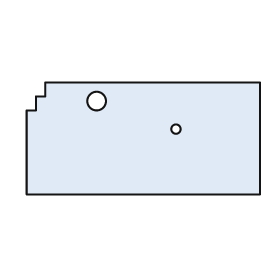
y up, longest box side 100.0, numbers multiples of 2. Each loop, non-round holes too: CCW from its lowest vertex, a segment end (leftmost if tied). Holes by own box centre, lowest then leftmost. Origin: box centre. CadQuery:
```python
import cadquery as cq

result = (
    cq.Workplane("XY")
    .moveTo(-50.0, -24.0)
    .lineTo(50.0, -24.0)
    .lineTo(50.0, 24.0)
    .lineTo(-42.0, 24.0)
    .lineTo(-42.0, 18.0)
    .lineTo(-46.0, 18.0)
    .lineTo(-46.0, 12.0)
    .lineTo(-50.0, 12.0)
    .close()
    .moveTo(14.0, 4.0)
    .circle(2.0)
    .moveTo(-20.0, 16.0)
    .circle(4.0)
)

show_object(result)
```